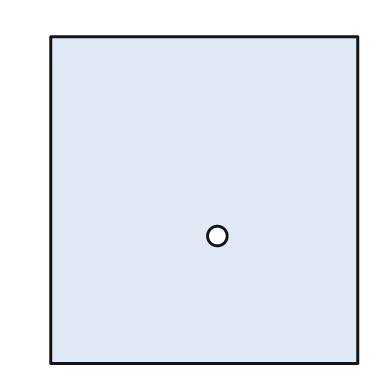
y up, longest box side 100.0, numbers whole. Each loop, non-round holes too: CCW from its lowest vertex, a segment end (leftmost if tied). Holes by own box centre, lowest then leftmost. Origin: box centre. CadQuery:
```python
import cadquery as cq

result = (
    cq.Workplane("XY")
    .moveTo(-47.0, -50.0)
    .lineTo(47.0, -50.0)
    .lineTo(47.0, 50.0)
    .lineTo(-47.0, 50.0)
    .close()
    .moveTo(4.0, -11.0)
    .circle(3.0)
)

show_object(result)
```